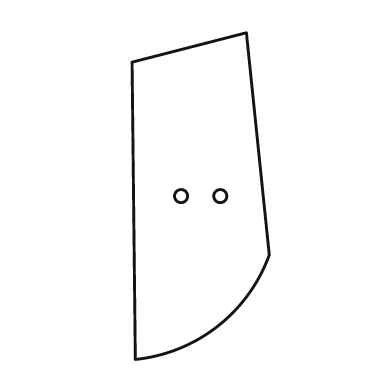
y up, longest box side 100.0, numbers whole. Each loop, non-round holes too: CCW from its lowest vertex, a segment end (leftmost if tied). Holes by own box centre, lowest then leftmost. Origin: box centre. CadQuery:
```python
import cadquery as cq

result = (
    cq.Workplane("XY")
    .moveTo(-20.0, -50.0)
    .threePointArc((5.0, -40.0), (21.0, -18.0))
    .lineTo(14.0, 50.0)
    .lineTo(-21.0, 41.0)
    .close()
    .moveTo(-6.0, 0.0)
    .circle(2.0)
    .moveTo(6.0, 0.0)
    .circle(2.0)
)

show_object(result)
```